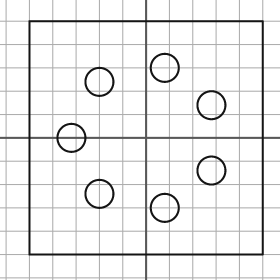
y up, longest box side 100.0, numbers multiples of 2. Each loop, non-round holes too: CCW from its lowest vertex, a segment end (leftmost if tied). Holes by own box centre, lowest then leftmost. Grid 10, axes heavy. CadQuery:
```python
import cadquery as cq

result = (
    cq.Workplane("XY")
    .moveTo(-50.0, -50.0)
    .lineTo(50.0, -50.0)
    .lineTo(50.0, 50.0)
    .lineTo(-50.0, 50.0)
    .close()
    .moveTo(8.0, -30.0)
    .circle(6.0)
    .moveTo(-20.0, -24.0)
    .circle(6.0)
    .moveTo(28.0, -14.0)
    .circle(6.0)
    .moveTo(-32.0, 0.0)
    .circle(6.0)
    .moveTo(28.0, 14.0)
    .circle(6.0)
    .moveTo(-20.0, 24.0)
    .circle(6.0)
    .moveTo(8.0, 30.0)
    .circle(6.0)
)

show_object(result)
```